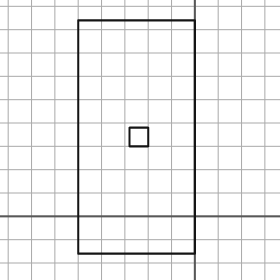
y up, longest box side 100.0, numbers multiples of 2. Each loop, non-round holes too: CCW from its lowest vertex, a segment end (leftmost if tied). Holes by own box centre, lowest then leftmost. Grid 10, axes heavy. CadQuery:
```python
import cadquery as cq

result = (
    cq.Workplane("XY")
    .moveTo(-50.0, -16.0)
    .lineTo(0.0, -16.0)
    .lineTo(0.0, 84.0)
    .lineTo(-50.0, 84.0)
    .close()
    .moveTo(-28.0, 30.0)
    .lineTo(-20.0, 30.0)
    .lineTo(-20.0, 38.0)
    .lineTo(-28.0, 38.0)
    .close()
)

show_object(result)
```